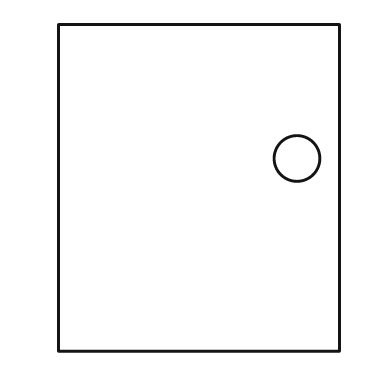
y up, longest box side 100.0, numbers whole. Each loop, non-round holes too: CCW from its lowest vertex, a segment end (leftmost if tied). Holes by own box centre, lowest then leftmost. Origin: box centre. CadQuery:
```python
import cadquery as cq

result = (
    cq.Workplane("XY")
    .moveTo(-43.0, -50.0)
    .lineTo(43.0, -50.0)
    .lineTo(43.0, 50.0)
    .lineTo(-43.0, 50.0)
    .close()
    .moveTo(30.0, 9.0)
    .circle(7.0)
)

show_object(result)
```